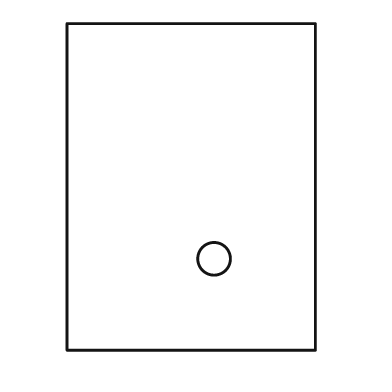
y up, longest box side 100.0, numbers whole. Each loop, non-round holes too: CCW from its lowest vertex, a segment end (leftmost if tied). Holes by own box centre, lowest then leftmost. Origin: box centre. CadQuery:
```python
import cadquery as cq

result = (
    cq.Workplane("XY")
    .moveTo(-38.0, -50.0)
    .lineTo(38.0, -50.0)
    .lineTo(38.0, 50.0)
    .lineTo(-38.0, 50.0)
    .close()
    .moveTo(7.0, -22.0)
    .circle(5.0)
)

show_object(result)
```